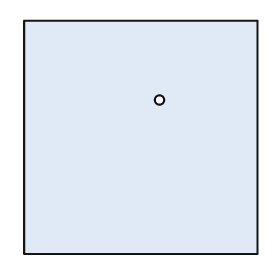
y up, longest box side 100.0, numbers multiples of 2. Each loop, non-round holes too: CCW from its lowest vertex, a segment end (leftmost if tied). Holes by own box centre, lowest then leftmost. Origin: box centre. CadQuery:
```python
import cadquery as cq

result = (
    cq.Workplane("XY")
    .moveTo(-50.0, -50.0)
    .lineTo(50.0, -50.0)
    .lineTo(50.0, 50.0)
    .lineTo(-50.0, 50.0)
    .close()
    .moveTo(8.0, 16.0)
    .circle(2.0)
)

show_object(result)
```